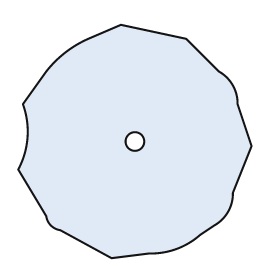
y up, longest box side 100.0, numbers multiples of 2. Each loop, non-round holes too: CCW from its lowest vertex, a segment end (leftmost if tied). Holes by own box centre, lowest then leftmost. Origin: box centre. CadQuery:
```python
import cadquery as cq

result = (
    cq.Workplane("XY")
    .moveTo(-10.0, -50.0)
    .lineTo(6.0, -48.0)
    .threePointArc((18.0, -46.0), (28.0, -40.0))
    .lineTo(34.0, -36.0)
    .threePointArc((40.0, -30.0), (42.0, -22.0))
    .lineTo(50.0, -2.0)
    .lineTo(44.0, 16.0)
    .threePointArc((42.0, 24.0), (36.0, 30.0))
    .lineTo(22.0, 44.0)
    .lineTo(-6.0, 50.0)
    .lineTo(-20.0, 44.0)
    .threePointArc((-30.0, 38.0), (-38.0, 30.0))
    .lineTo(-48.0, 16.0)
    .threePointArc((-46.0, 2.0), (-50.0, -12.0))
    .lineTo(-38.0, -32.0)
    .threePointArc((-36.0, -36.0), (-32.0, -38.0))
    .close()
    .moveTo(0.0, 0.0)
    .circle(4.0)
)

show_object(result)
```